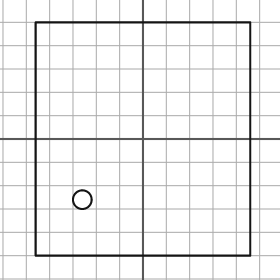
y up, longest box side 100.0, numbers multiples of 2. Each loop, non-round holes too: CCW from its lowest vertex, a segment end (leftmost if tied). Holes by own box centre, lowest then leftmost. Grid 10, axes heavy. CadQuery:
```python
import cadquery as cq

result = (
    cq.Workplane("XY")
    .moveTo(-46.0, -50.0)
    .lineTo(46.0, -50.0)
    .lineTo(46.0, 50.0)
    .lineTo(-46.0, 50.0)
    .close()
    .moveTo(-26.0, -26.0)
    .circle(4.0)
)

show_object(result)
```